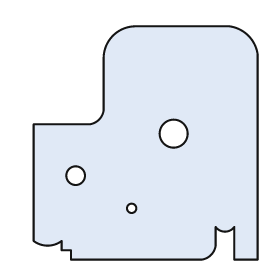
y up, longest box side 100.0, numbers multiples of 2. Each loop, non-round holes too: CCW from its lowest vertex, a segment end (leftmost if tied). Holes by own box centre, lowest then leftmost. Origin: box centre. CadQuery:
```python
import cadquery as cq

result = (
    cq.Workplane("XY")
    .moveTo(-32.0, -50.0)
    .lineTo(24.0, -50.0)
    .threePointArc((28.0, -48.0), (30.0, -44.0))
    .lineTo(30.0, -36.0)
    .threePointArc((34.0, -38.0), (38.0, -36.0))
    .lineTo(38.0, -50.0)
    .lineTo(48.0, -50.0)
    .lineTo(48.0, 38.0)
    .threePointArc((44.0, 46.0), (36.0, 50.0))
    .lineTo(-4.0, 50.0)
    .threePointArc((-14.0, 46.0), (-18.0, 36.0))
    .lineTo(-18.0, 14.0)
    .threePointArc((-20.0, 10.0), (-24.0, 8.0))
    .lineTo(-48.0, 8.0)
    .lineTo(-48.0, -42.0)
    .threePointArc((-42.0, -44.0), (-36.0, -42.0))
    .lineTo(-36.0, -46.0)
    .lineTo(-32.0, -46.0)
    .close()
    .moveTo(-6.0, -28.0)
    .circle(2.0)
    .moveTo(-30.0, -14.0)
    .circle(4.0)
    .moveTo(12.0, 4.0)
    .circle(6.0)
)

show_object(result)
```